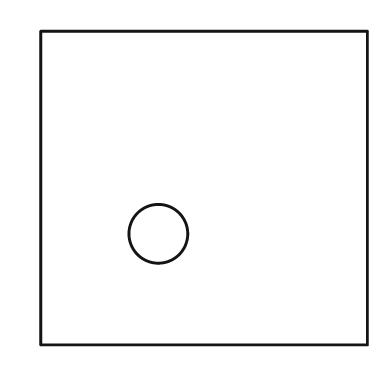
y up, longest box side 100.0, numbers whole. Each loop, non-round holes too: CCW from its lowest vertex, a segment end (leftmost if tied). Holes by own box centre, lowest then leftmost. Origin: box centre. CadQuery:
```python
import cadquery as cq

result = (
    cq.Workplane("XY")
    .moveTo(-50.0, -48.0)
    .lineTo(50.0, -48.0)
    .lineTo(50.0, 48.0)
    .lineTo(-50.0, 48.0)
    .close()
    .moveTo(-14.0, -14.0)
    .circle(9.0)
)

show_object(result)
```